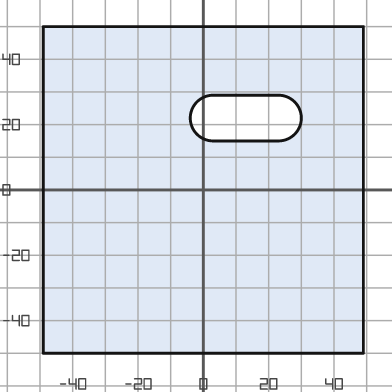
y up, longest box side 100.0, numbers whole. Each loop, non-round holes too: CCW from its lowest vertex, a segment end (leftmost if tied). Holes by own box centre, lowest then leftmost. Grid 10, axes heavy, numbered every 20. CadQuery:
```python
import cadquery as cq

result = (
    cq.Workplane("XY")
    .moveTo(-49.0, -50.0)
    .lineTo(49.0, -50.0)
    .lineTo(49.0, 50.0)
    .lineTo(-49.0, 50.0)
    .close()
    .moveTo(3.0, 15.0)
    .lineTo(23.0, 15.0)
    .threePointArc((30.0, 22.0), (23.0, 29.0))
    .lineTo(3.0, 29.0)
    .threePointArc((-4.0, 22.0), (3.0, 15.0))
    .close()
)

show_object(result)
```